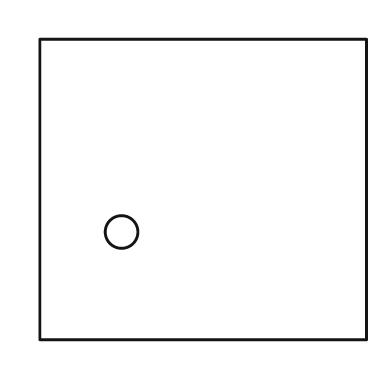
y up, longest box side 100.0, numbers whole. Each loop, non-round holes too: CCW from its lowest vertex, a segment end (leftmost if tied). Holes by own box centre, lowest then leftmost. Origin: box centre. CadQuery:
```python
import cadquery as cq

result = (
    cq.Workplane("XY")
    .moveTo(-50.0, -46.0)
    .lineTo(50.0, -46.0)
    .lineTo(50.0, 46.0)
    .lineTo(-50.0, 46.0)
    .close()
    .moveTo(-25.0, -13.0)
    .circle(5.0)
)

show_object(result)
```